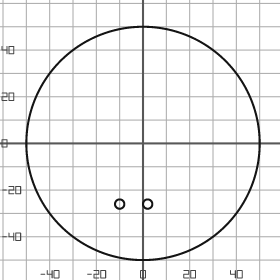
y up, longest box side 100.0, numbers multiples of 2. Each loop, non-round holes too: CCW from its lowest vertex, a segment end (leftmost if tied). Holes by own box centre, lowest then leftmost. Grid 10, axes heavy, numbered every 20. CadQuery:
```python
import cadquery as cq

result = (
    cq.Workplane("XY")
    .moveTo(0.0, 0.0)
    .circle(50.0)
    .moveTo(-10.0, -26.0)
    .circle(2.0)
    .moveTo(2.0, -26.0)
    .circle(2.0)
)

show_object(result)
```